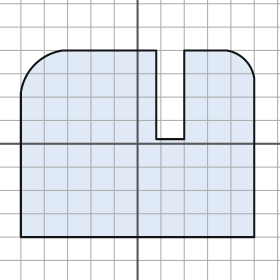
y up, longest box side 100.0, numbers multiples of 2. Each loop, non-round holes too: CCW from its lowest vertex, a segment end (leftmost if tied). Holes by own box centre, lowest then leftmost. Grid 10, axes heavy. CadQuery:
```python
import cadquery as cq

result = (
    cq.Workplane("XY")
    .moveTo(-50.0, -40.0)
    .lineTo(50.0, -40.0)
    .lineTo(50.0, 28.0)
    .threePointArc((46.0, 36.0), (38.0, 40.0))
    .lineTo(20.0, 40.0)
    .lineTo(20.0, 2.0)
    .lineTo(8.0, 2.0)
    .lineTo(8.0, 40.0)
    .lineTo(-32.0, 40.0)
    .threePointArc((-44.0, 34.0), (-50.0, 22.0))
    .close()
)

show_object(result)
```